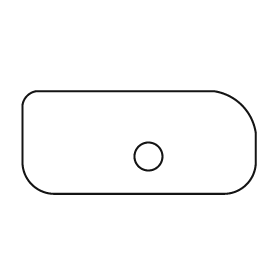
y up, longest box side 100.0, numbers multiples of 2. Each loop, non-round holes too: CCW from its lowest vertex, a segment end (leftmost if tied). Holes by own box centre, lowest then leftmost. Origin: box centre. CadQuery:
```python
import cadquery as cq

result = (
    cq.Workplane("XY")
    .moveTo(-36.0, -22.0)
    .lineTo(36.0, -22.0)
    .threePointArc((46.0, -18.0), (50.0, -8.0))
    .lineTo(50.0, 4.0)
    .threePointArc((44.0, 16.0), (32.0, 22.0))
    .lineTo(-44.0, 22.0)
    .threePointArc((-48.0, 20.0), (-50.0, 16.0))
    .lineTo(-50.0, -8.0)
    .threePointArc((-46.0, -18.0), (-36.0, -22.0))
    .close()
    .moveTo(4.0, -6.0)
    .circle(6.0)
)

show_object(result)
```